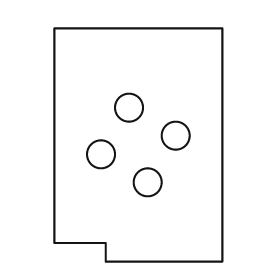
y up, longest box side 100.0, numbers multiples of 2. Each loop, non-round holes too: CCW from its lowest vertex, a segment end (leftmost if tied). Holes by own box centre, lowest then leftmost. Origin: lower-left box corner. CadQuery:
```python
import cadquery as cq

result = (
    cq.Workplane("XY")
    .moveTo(22.0, 0.0)
    .lineTo(72.0, 0.0)
    .lineTo(72.0, 100.0)
    .lineTo(0.0, 100.0)
    .lineTo(0.0, 8.0)
    .lineTo(22.0, 8.0)
    .close()
    .moveTo(40.0, 34.0)
    .circle(6.0)
    .moveTo(20.0, 46.0)
    .circle(6.0)
    .moveTo(52.0, 54.0)
    .circle(6.0)
    .moveTo(32.0, 66.0)
    .circle(6.0)
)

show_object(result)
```